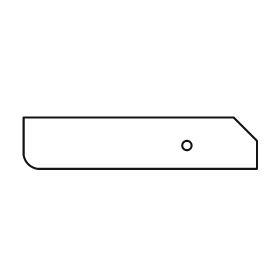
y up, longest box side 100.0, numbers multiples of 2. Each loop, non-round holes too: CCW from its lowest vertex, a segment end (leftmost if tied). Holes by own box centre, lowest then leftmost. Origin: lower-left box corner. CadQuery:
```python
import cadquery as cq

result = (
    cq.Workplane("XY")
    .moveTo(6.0, 0.0)
    .lineTo(100.0, 0.0)
    .lineTo(100.0, 12.0)
    .lineTo(90.0, 22.0)
    .lineTo(0.0, 22.0)
    .lineTo(0.0, 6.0)
    .threePointArc((2.0, 2.0), (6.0, 0.0))
    .close()
    .moveTo(70.0, 10.0)
    .circle(2.0)
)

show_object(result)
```